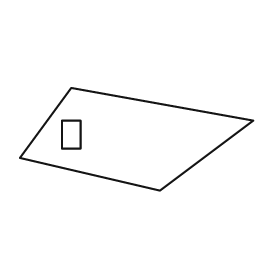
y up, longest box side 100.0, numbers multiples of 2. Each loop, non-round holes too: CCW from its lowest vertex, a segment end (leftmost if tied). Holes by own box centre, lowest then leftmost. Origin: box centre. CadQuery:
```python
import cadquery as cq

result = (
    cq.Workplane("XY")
    .moveTo(10.0, -22.0)
    .lineTo(50.0, 8.0)
    .lineTo(-28.0, 22.0)
    .lineTo(-50.0, -8.0)
    .close()
    .moveTo(-32.0, -4.0)
    .lineTo(-24.0, -4.0)
    .lineTo(-24.0, 8.0)
    .lineTo(-32.0, 8.0)
    .close()
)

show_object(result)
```